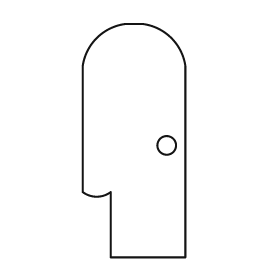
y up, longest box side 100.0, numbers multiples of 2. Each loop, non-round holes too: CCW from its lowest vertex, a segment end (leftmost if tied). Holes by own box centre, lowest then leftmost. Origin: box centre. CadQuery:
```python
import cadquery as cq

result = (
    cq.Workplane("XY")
    .moveTo(-10.0, -50.0)
    .lineTo(22.0, -50.0)
    .lineTo(22.0, 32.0)
    .threePointArc((16.0, 44.0), (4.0, 50.0))
    .lineTo(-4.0, 50.0)
    .threePointArc((-16.0, 44.0), (-22.0, 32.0))
    .lineTo(-22.0, -22.0)
    .threePointArc((-16.0, -24.0), (-10.0, -22.0))
    .close()
    .moveTo(14.0, -2.0)
    .circle(4.0)
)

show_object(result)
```